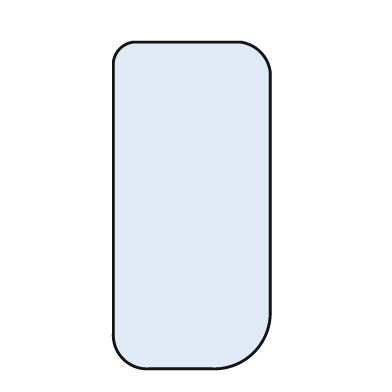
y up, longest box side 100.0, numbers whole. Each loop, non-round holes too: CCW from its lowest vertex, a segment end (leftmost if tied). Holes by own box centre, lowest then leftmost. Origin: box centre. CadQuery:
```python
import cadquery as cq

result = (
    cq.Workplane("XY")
    .moveTo(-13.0, -50.0)
    .lineTo(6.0, -50.0)
    .threePointArc((19.0, -45.0), (24.0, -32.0))
    .lineTo(24.0, 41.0)
    .threePointArc((21.0, 47.0), (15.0, 50.0))
    .lineTo(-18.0, 50.0)
    .threePointArc((-22.0, 48.0), (-24.0, 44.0))
    .lineTo(-24.0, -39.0)
    .threePointArc((-21.0, -47.0), (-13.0, -50.0))
    .close()
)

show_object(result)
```